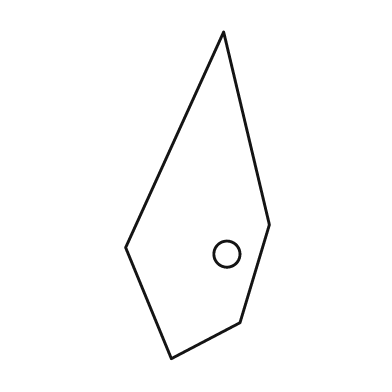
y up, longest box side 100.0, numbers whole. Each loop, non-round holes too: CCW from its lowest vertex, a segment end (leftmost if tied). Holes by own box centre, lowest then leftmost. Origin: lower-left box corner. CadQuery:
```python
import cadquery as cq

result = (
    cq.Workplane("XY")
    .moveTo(14.0, 0.0)
    .lineTo(35.0, 11.0)
    .lineTo(44.0, 41.0)
    .lineTo(30.0, 100.0)
    .lineTo(0.0, 34.0)
    .close()
    .moveTo(31.0, 32.0)
    .circle(4.0)
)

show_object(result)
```